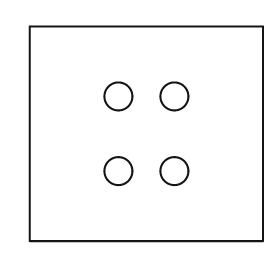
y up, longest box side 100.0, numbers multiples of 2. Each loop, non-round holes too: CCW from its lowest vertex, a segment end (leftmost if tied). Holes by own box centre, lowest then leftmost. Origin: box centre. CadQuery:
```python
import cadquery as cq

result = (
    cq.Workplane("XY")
    .moveTo(-50.0, -46.0)
    .lineTo(50.0, -46.0)
    .lineTo(50.0, 46.0)
    .lineTo(-50.0, 46.0)
    .close()
    .moveTo(-12.0, -16.0)
    .circle(6.0)
    .moveTo(12.0, -16.0)
    .circle(6.0)
    .moveTo(-12.0, 16.0)
    .circle(6.0)
    .moveTo(12.0, 16.0)
    .circle(6.0)
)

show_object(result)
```